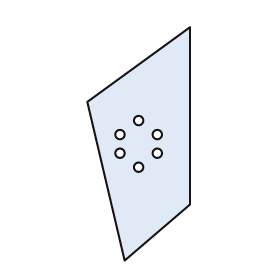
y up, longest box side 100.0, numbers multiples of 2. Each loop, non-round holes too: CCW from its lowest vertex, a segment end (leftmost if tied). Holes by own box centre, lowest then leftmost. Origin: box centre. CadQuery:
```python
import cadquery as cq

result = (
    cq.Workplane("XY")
    .moveTo(-6.0, -50.0)
    .lineTo(22.0, -26.0)
    .lineTo(22.0, 50.0)
    .lineTo(-22.0, 18.0)
    .close()
    .moveTo(0.0, -10.0)
    .circle(2.0)
    .moveTo(-8.0, -4.0)
    .circle(2.0)
    .moveTo(8.0, -4.0)
    .circle(2.0)
    .moveTo(-8.0, 4.0)
    .circle(2.0)
    .moveTo(8.0, 4.0)
    .circle(2.0)
    .moveTo(0.0, 10.0)
    .circle(2.0)
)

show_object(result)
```